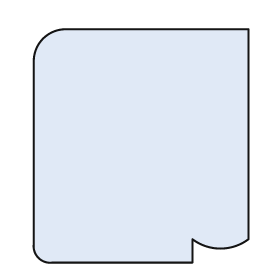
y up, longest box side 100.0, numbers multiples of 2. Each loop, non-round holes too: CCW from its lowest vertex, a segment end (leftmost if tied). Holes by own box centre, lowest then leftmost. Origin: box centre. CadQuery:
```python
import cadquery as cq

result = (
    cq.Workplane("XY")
    .moveTo(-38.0, -50.0)
    .lineTo(22.0, -50.0)
    .lineTo(22.0, -40.0)
    .threePointArc((34.0, -44.0), (46.0, -40.0))
    .lineTo(46.0, 50.0)
    .lineTo(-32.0, 50.0)
    .threePointArc((-42.0, 46.0), (-46.0, 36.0))
    .lineTo(-46.0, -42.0)
    .threePointArc((-44.0, -48.0), (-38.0, -50.0))
    .close()
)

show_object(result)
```